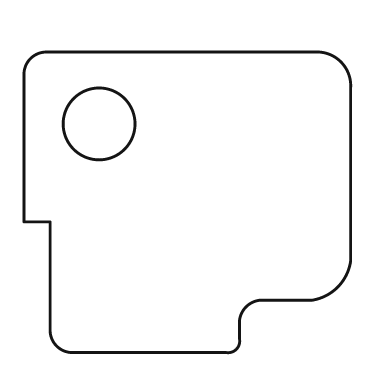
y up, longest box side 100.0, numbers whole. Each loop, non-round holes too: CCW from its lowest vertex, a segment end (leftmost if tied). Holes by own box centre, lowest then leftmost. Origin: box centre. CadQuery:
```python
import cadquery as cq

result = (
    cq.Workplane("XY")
    .moveTo(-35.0, -46.0)
    .lineTo(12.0, -46.0)
    .threePointArc((15.0, -45.0), (16.0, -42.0))
    .lineTo(16.0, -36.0)
    .threePointArc((18.0, -32.0), (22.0, -30.0))
    .lineTo(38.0, -30.0)
    .threePointArc((46.0, -26.0), (50.0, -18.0))
    .lineTo(50.0, 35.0)
    .threePointArc((47.0, 43.0), (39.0, 46.0))
    .lineTo(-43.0, 46.0)
    .threePointArc((-48.0, 44.0), (-50.0, 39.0))
    .lineTo(-50.0, -6.0)
    .lineTo(-42.0, -6.0)
    .lineTo(-42.0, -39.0)
    .threePointArc((-40.0, -44.0), (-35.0, -46.0))
    .close()
    .moveTo(-27.0, 24.0)
    .circle(11.0)
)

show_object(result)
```